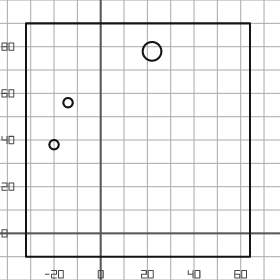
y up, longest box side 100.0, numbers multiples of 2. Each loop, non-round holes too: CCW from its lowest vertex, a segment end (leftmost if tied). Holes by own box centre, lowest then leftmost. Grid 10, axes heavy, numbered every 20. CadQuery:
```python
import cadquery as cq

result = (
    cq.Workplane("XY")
    .moveTo(-32.0, -10.0)
    .lineTo(64.0, -10.0)
    .lineTo(64.0, 90.0)
    .lineTo(-32.0, 90.0)
    .close()
    .moveTo(-20.0, 38.0)
    .circle(2.0)
    .moveTo(-14.0, 56.0)
    .circle(2.0)
    .moveTo(22.0, 78.0)
    .circle(4.0)
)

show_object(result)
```